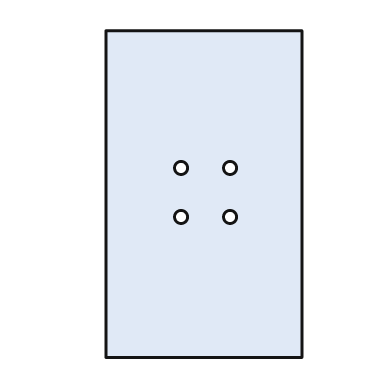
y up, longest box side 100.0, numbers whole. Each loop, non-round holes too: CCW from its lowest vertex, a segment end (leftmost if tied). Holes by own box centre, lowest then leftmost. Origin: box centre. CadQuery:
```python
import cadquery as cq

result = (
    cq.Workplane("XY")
    .moveTo(-30.0, -50.0)
    .lineTo(30.0, -50.0)
    .lineTo(30.0, 50.0)
    .lineTo(-30.0, 50.0)
    .close()
    .moveTo(-7.0, -7.0)
    .circle(2.0)
    .moveTo(8.0, -7.0)
    .circle(2.0)
    .moveTo(-7.0, 8.0)
    .circle(2.0)
    .moveTo(8.0, 8.0)
    .circle(2.0)
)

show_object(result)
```